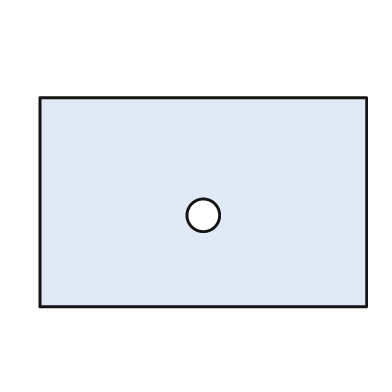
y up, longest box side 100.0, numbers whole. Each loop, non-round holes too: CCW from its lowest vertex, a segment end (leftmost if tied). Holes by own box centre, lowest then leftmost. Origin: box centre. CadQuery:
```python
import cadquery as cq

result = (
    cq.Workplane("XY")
    .moveTo(-50.0, -32.0)
    .lineTo(50.0, -32.0)
    .lineTo(50.0, 32.0)
    .lineTo(-50.0, 32.0)
    .close()
    .moveTo(0.0, -4.0)
    .circle(5.0)
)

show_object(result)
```